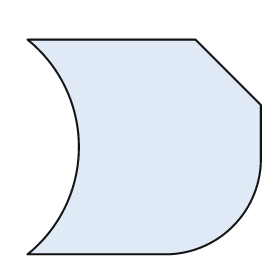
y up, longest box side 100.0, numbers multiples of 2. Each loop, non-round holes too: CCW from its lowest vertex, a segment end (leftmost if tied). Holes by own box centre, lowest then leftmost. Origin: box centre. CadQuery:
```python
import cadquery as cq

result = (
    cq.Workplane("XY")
    .moveTo(-50.0, -46.0)
    .lineTo(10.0, -46.0)
    .threePointArc((38.0, -34.0), (50.0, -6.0))
    .lineTo(50.0, 18.0)
    .lineTo(22.0, 46.0)
    .lineTo(-50.0, 46.0)
    .threePointArc((-28.0, 0.0), (-50.0, -46.0))
    .close()
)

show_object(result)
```